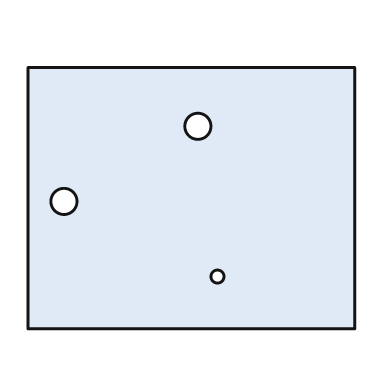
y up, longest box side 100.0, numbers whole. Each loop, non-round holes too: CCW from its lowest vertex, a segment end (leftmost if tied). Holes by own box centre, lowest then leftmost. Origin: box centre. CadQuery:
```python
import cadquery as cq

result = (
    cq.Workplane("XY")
    .moveTo(-50.0, -40.0)
    .lineTo(50.0, -40.0)
    .lineTo(50.0, 40.0)
    .lineTo(-50.0, 40.0)
    .close()
    .moveTo(8.0, -24.0)
    .circle(2.0)
    .moveTo(-39.0, -1.0)
    .circle(4.0)
    .moveTo(2.0, 22.0)
    .circle(4.0)
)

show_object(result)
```